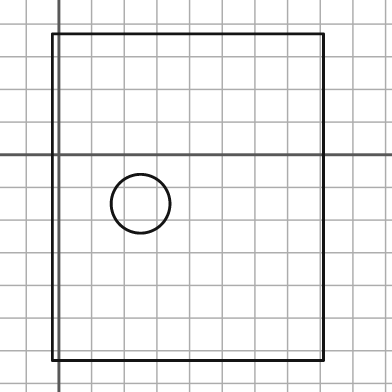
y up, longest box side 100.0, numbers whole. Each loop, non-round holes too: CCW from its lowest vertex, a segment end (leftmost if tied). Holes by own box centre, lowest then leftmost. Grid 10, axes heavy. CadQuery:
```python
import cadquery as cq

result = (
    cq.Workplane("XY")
    .moveTo(-2.0, -63.0)
    .lineTo(81.0, -63.0)
    .lineTo(81.0, 37.0)
    .lineTo(-2.0, 37.0)
    .close()
    .moveTo(25.0, -15.0)
    .circle(9.0)
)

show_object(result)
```